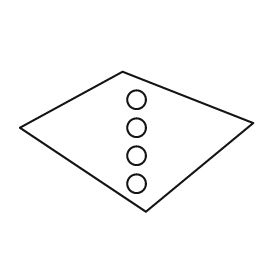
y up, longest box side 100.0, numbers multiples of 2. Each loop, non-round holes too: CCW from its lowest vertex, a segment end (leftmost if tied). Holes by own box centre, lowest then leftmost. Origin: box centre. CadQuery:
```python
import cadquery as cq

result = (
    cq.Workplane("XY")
    .moveTo(4.0, -30.0)
    .lineTo(50.0, 8.0)
    .lineTo(-6.0, 30.0)
    .lineTo(-50.0, 6.0)
    .close()
    .moveTo(0.0, -18.0)
    .circle(4.0)
    .moveTo(0.0, -6.0)
    .circle(4.0)
    .moveTo(0.0, 6.0)
    .circle(4.0)
    .moveTo(0.0, 18.0)
    .circle(4.0)
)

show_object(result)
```